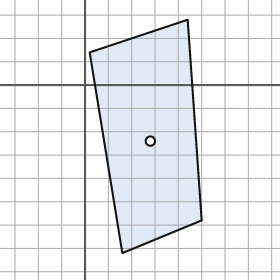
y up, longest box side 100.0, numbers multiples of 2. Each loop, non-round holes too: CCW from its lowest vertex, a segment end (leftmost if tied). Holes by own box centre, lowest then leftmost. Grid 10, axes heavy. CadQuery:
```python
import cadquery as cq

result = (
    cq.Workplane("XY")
    .moveTo(16.0, -72.0)
    .lineTo(50.0, -58.0)
    .lineTo(44.0, 28.0)
    .lineTo(2.0, 14.0)
    .close()
    .moveTo(28.0, -24.0)
    .circle(2.0)
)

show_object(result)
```